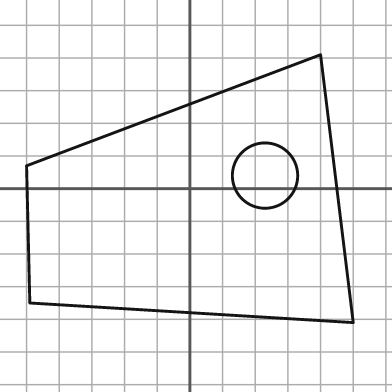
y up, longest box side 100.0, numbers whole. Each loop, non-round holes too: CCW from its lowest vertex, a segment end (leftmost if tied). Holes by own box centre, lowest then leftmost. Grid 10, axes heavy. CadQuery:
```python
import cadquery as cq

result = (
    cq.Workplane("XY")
    .moveTo(50.0, -41.0)
    .lineTo(40.0, 41.0)
    .lineTo(-50.0, 7.0)
    .lineTo(-49.0, -35.0)
    .close()
    .moveTo(23.0, 4.0)
    .circle(10.0)
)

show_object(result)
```